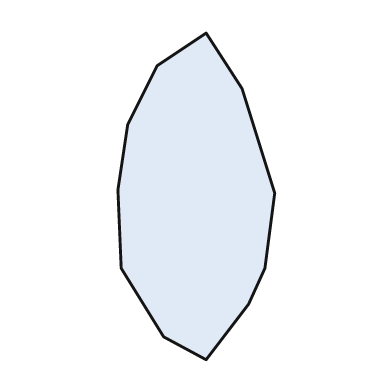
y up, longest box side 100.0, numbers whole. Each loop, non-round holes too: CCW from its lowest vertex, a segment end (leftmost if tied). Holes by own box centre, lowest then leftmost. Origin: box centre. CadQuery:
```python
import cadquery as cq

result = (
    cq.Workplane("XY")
    .moveTo(3.0, -50.0)
    .lineTo(16.0, -33.0)
    .lineTo(21.0, -22.0)
    .lineTo(24.0, 1.0)
    .lineTo(14.0, 33.0)
    .lineTo(3.0, 50.0)
    .lineTo(-12.0, 40.0)
    .lineTo(-21.0, 22.0)
    .lineTo(-24.0, 2.0)
    .lineTo(-23.0, -22.0)
    .lineTo(-10.0, -43.0)
    .close()
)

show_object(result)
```